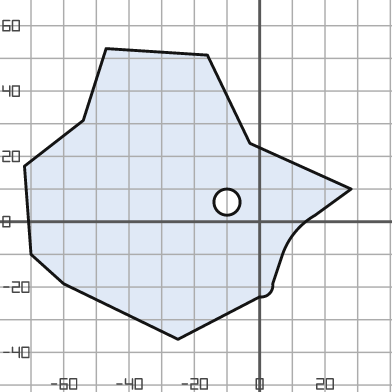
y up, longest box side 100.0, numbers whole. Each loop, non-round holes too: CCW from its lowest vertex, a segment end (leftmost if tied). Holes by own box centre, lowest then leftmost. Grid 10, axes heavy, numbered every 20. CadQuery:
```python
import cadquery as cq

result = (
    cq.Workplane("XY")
    .moveTo(-25.0, -36.0)
    .lineTo(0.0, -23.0)
    .threePointArc((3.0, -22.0), (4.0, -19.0))
    .lineTo(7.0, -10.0)
    .threePointArc((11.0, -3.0), (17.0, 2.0))
    .lineTo(28.0, 10.0)
    .lineTo(-3.0, 24.0)
    .lineTo(-16.0, 51.0)
    .lineTo(-47.0, 53.0)
    .lineTo(-54.0, 31.0)
    .lineTo(-72.0, 17.0)
    .lineTo(-70.0, -10.0)
    .lineTo(-60.0, -19.0)
    .close()
    .moveTo(-10.0, 6.0)
    .circle(4.0)
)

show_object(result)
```